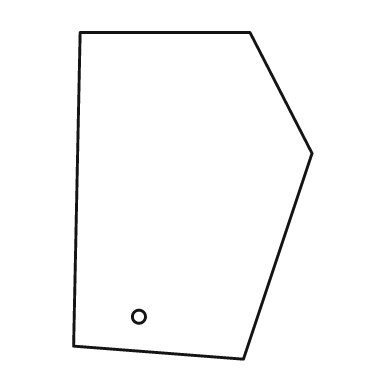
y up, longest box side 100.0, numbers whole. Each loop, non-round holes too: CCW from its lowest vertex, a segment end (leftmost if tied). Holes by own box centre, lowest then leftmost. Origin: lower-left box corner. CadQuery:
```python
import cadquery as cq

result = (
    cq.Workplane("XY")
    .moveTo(52.0, 0.0)
    .lineTo(73.0, 63.0)
    .lineTo(54.0, 100.0)
    .lineTo(2.0, 100.0)
    .lineTo(0.0, 4.0)
    .close()
    .moveTo(20.0, 13.0)
    .circle(2.0)
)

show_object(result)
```